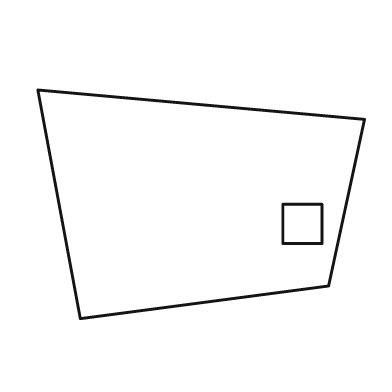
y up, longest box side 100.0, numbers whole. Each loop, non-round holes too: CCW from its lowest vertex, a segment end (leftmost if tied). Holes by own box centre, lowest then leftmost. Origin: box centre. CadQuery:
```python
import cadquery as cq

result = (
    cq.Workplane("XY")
    .moveTo(-37.0, -35.0)
    .lineTo(39.0, -25.0)
    .lineTo(50.0, 26.0)
    .lineTo(-50.0, 35.0)
    .close()
    .moveTo(25.0, -12.0)
    .lineTo(37.0, -12.0)
    .lineTo(37.0, 0.0)
    .lineTo(25.0, 0.0)
    .close()
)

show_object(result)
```